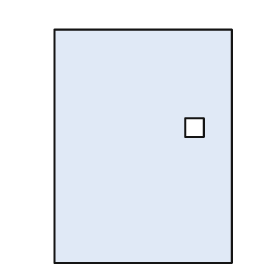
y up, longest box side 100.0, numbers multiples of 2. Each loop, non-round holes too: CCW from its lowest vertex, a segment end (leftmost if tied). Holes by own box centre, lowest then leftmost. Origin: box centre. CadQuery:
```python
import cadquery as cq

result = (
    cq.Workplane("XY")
    .moveTo(-38.0, -50.0)
    .lineTo(38.0, -50.0)
    .lineTo(38.0, 50.0)
    .lineTo(-38.0, 50.0)
    .close()
    .moveTo(18.0, 4.0)
    .lineTo(26.0, 4.0)
    .lineTo(26.0, 12.0)
    .lineTo(18.0, 12.0)
    .close()
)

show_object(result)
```